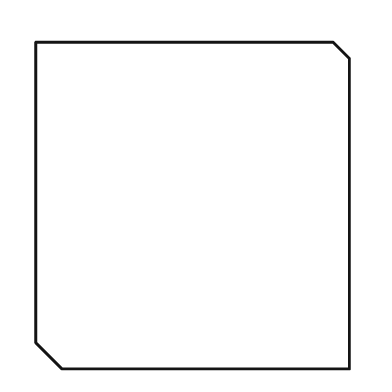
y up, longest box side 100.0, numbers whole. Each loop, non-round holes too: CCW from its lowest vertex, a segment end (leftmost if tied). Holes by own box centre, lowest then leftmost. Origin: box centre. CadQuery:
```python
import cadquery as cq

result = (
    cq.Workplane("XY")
    .moveTo(-40.0, -50.0)
    .lineTo(48.0, -50.0)
    .lineTo(48.0, 45.0)
    .lineTo(43.0, 50.0)
    .lineTo(-48.0, 50.0)
    .lineTo(-48.0, -42.0)
    .close()
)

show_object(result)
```